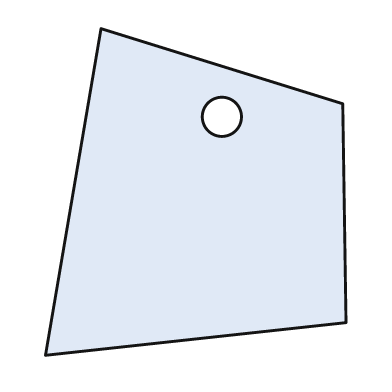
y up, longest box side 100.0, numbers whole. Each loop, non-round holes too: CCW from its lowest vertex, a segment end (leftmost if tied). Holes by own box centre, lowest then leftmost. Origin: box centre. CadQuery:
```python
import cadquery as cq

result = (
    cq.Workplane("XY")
    .moveTo(-46.0, -50.0)
    .lineTo(46.0, -40.0)
    .lineTo(45.0, 27.0)
    .lineTo(-29.0, 50.0)
    .close()
    .moveTo(8.0, 23.0)
    .circle(6.0)
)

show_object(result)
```